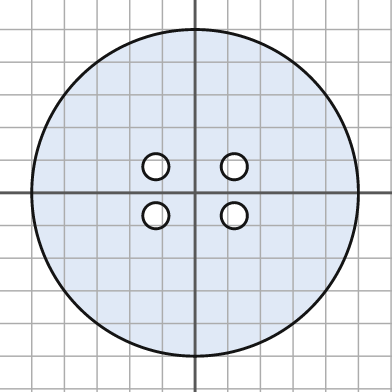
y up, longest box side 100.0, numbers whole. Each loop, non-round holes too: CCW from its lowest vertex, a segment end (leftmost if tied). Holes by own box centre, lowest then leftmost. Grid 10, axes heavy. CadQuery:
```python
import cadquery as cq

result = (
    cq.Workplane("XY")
    .moveTo(0.0, 0.0)
    .circle(50.0)
    .moveTo(-12.0, -7.0)
    .circle(4.0)
    .moveTo(12.0, -7.0)
    .circle(4.0)
    .moveTo(-12.0, 8.0)
    .circle(4.0)
    .moveTo(12.0, 8.0)
    .circle(4.0)
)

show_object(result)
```